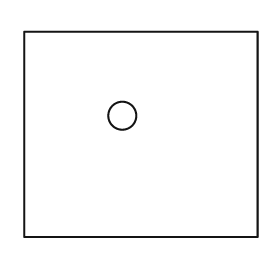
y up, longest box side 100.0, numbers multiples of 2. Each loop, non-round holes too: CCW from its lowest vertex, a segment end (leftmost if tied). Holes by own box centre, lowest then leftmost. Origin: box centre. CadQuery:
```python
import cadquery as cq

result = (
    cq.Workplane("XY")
    .moveTo(-50.0, -44.0)
    .lineTo(50.0, -44.0)
    .lineTo(50.0, 44.0)
    .lineTo(-50.0, 44.0)
    .close()
    .moveTo(-8.0, 8.0)
    .circle(6.0)
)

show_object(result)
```